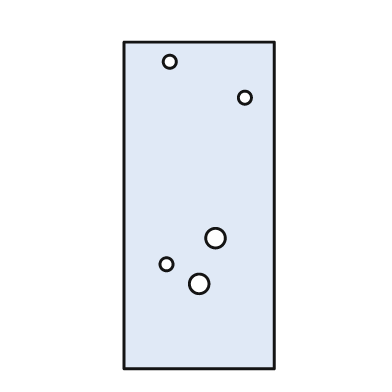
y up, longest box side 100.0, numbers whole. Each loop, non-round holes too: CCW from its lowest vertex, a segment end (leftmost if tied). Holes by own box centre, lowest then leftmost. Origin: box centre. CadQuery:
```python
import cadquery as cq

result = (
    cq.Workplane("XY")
    .moveTo(-23.0, -50.0)
    .lineTo(23.0, -50.0)
    .lineTo(23.0, 50.0)
    .lineTo(-23.0, 50.0)
    .close()
    .moveTo(0.0, -24.0)
    .circle(3.0)
    .moveTo(-10.0, -18.0)
    .circle(2.0)
    .moveTo(5.0, -10.0)
    .circle(3.0)
    .moveTo(14.0, 33.0)
    .circle(2.0)
    .moveTo(-9.0, 44.0)
    .circle(2.0)
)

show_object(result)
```